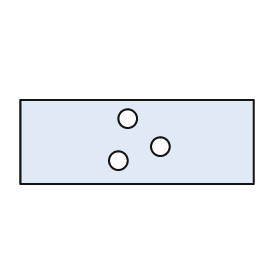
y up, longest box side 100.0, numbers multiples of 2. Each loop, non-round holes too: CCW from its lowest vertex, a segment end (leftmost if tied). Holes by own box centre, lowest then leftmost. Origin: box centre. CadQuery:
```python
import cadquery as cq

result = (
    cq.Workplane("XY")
    .moveTo(-50.0, -18.0)
    .lineTo(50.0, -18.0)
    .lineTo(50.0, 18.0)
    .lineTo(-50.0, 18.0)
    .close()
    .moveTo(-8.0, -8.0)
    .circle(4.0)
    .moveTo(10.0, -2.0)
    .circle(4.0)
    .moveTo(-4.0, 10.0)
    .circle(4.0)
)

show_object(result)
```